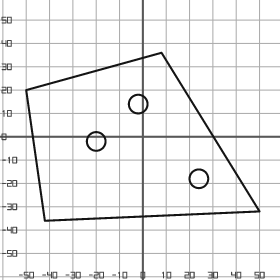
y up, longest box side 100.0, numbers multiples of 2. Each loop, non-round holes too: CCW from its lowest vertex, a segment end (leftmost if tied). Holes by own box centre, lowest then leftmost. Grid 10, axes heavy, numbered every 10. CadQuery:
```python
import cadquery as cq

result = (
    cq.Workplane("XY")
    .moveTo(-42.0, -36.0)
    .lineTo(50.0, -32.0)
    .lineTo(8.0, 36.0)
    .lineTo(-50.0, 20.0)
    .close()
    .moveTo(24.0, -18.0)
    .circle(4.0)
    .moveTo(-20.0, -2.0)
    .circle(4.0)
    .moveTo(-2.0, 14.0)
    .circle(4.0)
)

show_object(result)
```